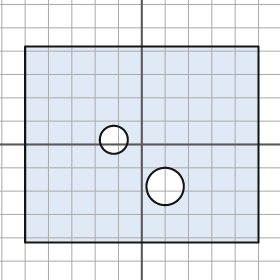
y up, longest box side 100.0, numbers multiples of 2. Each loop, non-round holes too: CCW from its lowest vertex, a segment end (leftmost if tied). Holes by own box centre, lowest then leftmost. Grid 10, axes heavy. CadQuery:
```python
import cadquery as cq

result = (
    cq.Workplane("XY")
    .moveTo(-50.0, -42.0)
    .lineTo(50.0, -42.0)
    .lineTo(50.0, 42.0)
    .lineTo(-50.0, 42.0)
    .close()
    .moveTo(10.0, -18.0)
    .circle(8.0)
    .moveTo(-12.0, 2.0)
    .circle(6.0)
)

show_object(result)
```